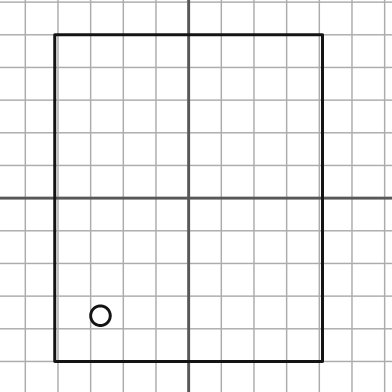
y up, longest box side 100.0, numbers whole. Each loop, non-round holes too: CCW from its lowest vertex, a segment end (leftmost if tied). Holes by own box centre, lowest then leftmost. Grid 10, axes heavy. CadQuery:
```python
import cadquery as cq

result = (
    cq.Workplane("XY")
    .moveTo(-41.0, -50.0)
    .lineTo(41.0, -50.0)
    .lineTo(41.0, 50.0)
    .lineTo(-41.0, 50.0)
    .close()
    .moveTo(-27.0, -36.0)
    .circle(3.0)
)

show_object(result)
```